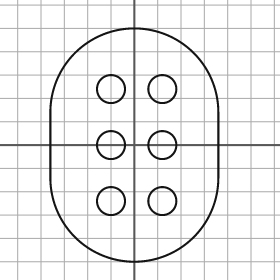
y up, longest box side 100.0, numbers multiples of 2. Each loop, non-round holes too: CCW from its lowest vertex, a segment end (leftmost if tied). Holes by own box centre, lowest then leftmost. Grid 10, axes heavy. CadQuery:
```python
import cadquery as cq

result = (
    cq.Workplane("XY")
    .moveTo(-36.0, -14.0)
    .threePointArc((0.0, -50.0), (36.0, -14.0))
    .lineTo(36.0, 14.0)
    .threePointArc((0.0, 50.0), (-36.0, 14.0))
    .close()
    .moveTo(-10.0, -24.0)
    .circle(6.0)
    .moveTo(12.0, -24.0)
    .circle(6.0)
    .moveTo(-10.0, 0.0)
    .circle(6.0)
    .moveTo(12.0, 0.0)
    .circle(6.0)
    .moveTo(-10.0, 24.0)
    .circle(6.0)
    .moveTo(12.0, 24.0)
    .circle(6.0)
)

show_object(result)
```